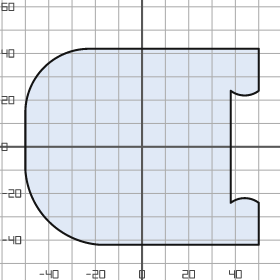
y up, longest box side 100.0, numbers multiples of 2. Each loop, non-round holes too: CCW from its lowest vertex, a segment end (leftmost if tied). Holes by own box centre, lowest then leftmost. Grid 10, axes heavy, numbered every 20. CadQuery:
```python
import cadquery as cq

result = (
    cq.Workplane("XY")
    .moveTo(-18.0, -42.0)
    .lineTo(50.0, -42.0)
    .lineTo(50.0, -24.0)
    .threePointArc((44.0, -22.0), (38.0, -24.0))
    .lineTo(38.0, 24.0)
    .threePointArc((44.0, 22.0), (50.0, 24.0))
    .lineTo(50.0, 42.0)
    .lineTo(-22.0, 42.0)
    .threePointArc((-42.0, 34.0), (-50.0, 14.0))
    .lineTo(-50.0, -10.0)
    .threePointArc((-40.0, -32.0), (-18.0, -42.0))
    .close()
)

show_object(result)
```